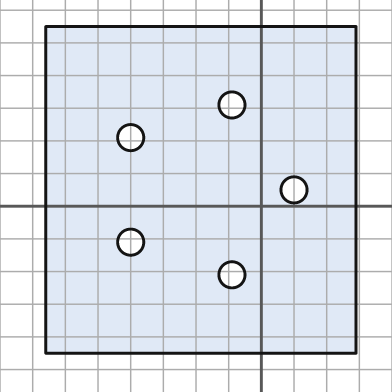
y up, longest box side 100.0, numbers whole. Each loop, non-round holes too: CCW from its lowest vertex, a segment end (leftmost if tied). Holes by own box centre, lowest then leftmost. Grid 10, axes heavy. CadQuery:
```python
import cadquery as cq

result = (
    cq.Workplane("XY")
    .moveTo(-66.0, -45.0)
    .lineTo(29.0, -45.0)
    .lineTo(29.0, 55.0)
    .lineTo(-66.0, 55.0)
    .close()
    .moveTo(-9.0, -21.0)
    .circle(4.0)
    .moveTo(-40.0, -11.0)
    .circle(4.0)
    .moveTo(10.0, 5.0)
    .circle(4.0)
    .moveTo(-40.0, 21.0)
    .circle(4.0)
    .moveTo(-9.0, 31.0)
    .circle(4.0)
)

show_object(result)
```